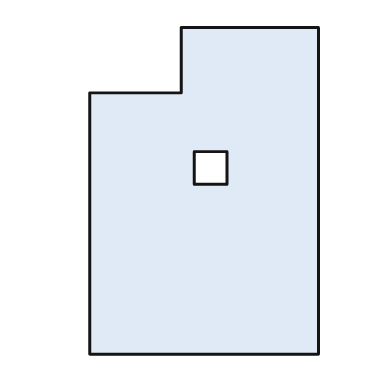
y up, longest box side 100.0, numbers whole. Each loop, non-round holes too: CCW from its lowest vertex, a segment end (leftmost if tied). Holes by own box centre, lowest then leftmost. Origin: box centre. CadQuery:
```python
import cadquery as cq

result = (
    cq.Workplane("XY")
    .moveTo(-35.0, -50.0)
    .lineTo(35.0, -50.0)
    .lineTo(35.0, 50.0)
    .lineTo(-7.0, 50.0)
    .lineTo(-7.0, 30.0)
    .lineTo(-35.0, 30.0)
    .close()
    .moveTo(-3.0, 2.0)
    .lineTo(7.0, 2.0)
    .lineTo(7.0, 12.0)
    .lineTo(-3.0, 12.0)
    .close()
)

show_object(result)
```